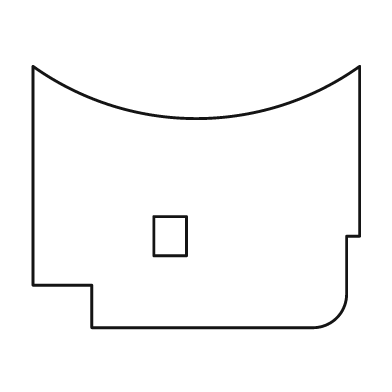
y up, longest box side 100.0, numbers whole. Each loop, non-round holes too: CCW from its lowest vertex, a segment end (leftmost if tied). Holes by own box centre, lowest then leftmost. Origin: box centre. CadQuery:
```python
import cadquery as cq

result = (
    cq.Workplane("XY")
    .moveTo(-32.0, -40.0)
    .lineTo(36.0, -40.0)
    .threePointArc((43.0, -37.0), (46.0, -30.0))
    .lineTo(46.0, -12.0)
    .lineTo(50.0, -12.0)
    .lineTo(50.0, 40.0)
    .threePointArc((0.0, 24.0), (-50.0, 40.0))
    .lineTo(-50.0, -27.0)
    .lineTo(-32.0, -27.0)
    .close()
    .moveTo(-13.0, -18.0)
    .lineTo(-3.0, -18.0)
    .lineTo(-3.0, -6.0)
    .lineTo(-13.0, -6.0)
    .close()
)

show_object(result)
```